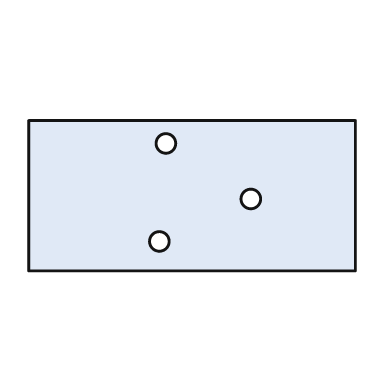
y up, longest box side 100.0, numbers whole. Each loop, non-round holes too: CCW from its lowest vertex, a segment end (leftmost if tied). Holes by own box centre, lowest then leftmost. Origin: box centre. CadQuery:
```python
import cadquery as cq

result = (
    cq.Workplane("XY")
    .moveTo(-50.0, -23.0)
    .lineTo(50.0, -23.0)
    .lineTo(50.0, 23.0)
    .lineTo(-50.0, 23.0)
    .close()
    .moveTo(-10.0, -14.0)
    .circle(3.0)
    .moveTo(18.0, -1.0)
    .circle(3.0)
    .moveTo(-8.0, 16.0)
    .circle(3.0)
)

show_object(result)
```